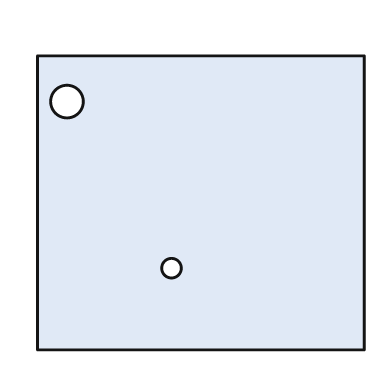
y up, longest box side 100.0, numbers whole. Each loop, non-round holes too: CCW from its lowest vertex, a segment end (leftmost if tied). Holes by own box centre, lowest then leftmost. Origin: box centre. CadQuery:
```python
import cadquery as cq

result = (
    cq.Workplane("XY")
    .moveTo(-50.0, -45.0)
    .lineTo(50.0, -45.0)
    .lineTo(50.0, 45.0)
    .lineTo(-50.0, 45.0)
    .close()
    .moveTo(-9.0, -20.0)
    .circle(3.0)
    .moveTo(-41.0, 31.0)
    .circle(5.0)
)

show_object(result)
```